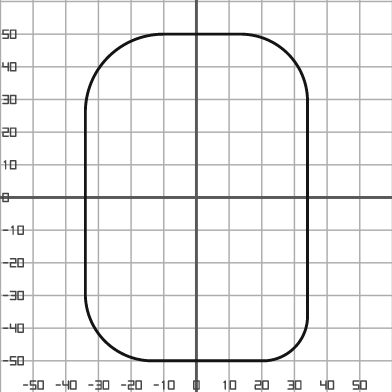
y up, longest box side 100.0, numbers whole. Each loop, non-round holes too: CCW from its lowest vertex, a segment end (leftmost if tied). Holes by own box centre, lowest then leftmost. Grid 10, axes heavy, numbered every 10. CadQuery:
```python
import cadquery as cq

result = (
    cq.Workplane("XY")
    .moveTo(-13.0, -50.0)
    .lineTo(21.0, -50.0)
    .threePointArc((30.0, -46.0), (34.0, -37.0))
    .lineTo(34.0, 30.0)
    .threePointArc((28.0, 44.0), (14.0, 50.0))
    .lineTo(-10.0, 50.0)
    .threePointArc((-27.0, 43.0), (-34.0, 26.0))
    .lineTo(-34.0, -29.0)
    .threePointArc((-28.0, -44.0), (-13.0, -50.0))
    .close()
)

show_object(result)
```